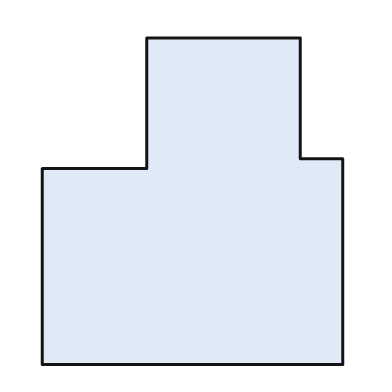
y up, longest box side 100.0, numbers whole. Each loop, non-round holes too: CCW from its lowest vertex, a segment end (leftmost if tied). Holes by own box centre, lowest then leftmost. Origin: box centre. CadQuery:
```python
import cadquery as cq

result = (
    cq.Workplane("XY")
    .moveTo(-46.0, -50.0)
    .lineTo(46.0, -50.0)
    .lineTo(46.0, 13.0)
    .lineTo(33.0, 13.0)
    .lineTo(33.0, 50.0)
    .lineTo(-14.0, 50.0)
    .lineTo(-14.0, 10.0)
    .lineTo(-46.0, 10.0)
    .close()
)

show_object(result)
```